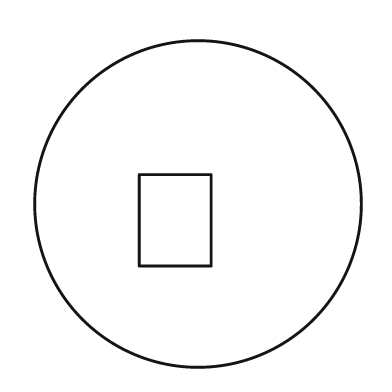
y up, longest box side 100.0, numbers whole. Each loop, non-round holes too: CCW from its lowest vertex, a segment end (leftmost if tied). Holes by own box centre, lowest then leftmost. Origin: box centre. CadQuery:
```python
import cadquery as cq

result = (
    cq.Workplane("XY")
    .moveTo(0.0, 0.0)
    .circle(50.0)
    .moveTo(-18.0, -19.0)
    .lineTo(4.0, -19.0)
    .lineTo(4.0, 9.0)
    .lineTo(-18.0, 9.0)
    .close()
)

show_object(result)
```